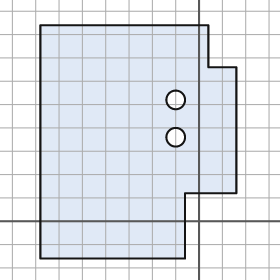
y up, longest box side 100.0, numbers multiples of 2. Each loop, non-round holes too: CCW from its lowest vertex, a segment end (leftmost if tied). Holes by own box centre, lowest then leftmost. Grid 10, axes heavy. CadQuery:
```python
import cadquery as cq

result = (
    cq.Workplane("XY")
    .moveTo(-68.0, -16.0)
    .lineTo(-6.0, -16.0)
    .lineTo(-6.0, 12.0)
    .lineTo(16.0, 12.0)
    .lineTo(16.0, 66.0)
    .lineTo(4.0, 66.0)
    .lineTo(4.0, 84.0)
    .lineTo(-68.0, 84.0)
    .close()
    .moveTo(-10.0, 36.0)
    .circle(4.0)
    .moveTo(-10.0, 52.0)
    .circle(4.0)
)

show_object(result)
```